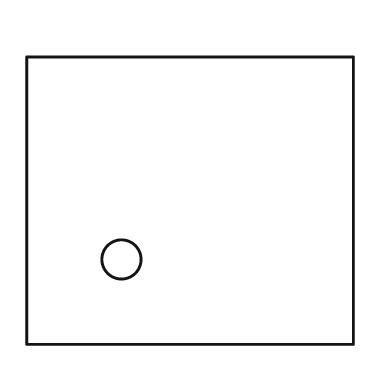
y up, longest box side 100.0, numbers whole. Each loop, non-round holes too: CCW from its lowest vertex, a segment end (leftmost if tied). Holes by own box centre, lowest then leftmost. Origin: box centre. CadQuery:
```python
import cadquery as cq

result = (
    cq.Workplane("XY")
    .moveTo(-50.0, -44.0)
    .lineTo(50.0, -44.0)
    .lineTo(50.0, 44.0)
    .lineTo(-50.0, 44.0)
    .close()
    .moveTo(-21.0, -18.0)
    .circle(6.0)
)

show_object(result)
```